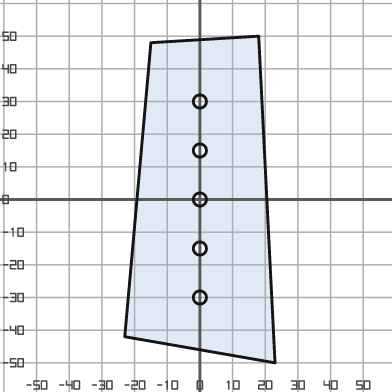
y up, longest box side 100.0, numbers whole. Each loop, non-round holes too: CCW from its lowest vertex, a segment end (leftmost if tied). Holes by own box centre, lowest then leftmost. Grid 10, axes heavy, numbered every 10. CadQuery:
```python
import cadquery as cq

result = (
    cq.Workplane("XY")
    .moveTo(23.0, -50.0)
    .lineTo(18.0, 50.0)
    .lineTo(-15.0, 48.0)
    .lineTo(-23.0, -42.0)
    .close()
    .moveTo(0.0, -30.0)
    .circle(2.0)
    .moveTo(0.0, -15.0)
    .circle(2.0)
    .moveTo(0.0, 0.0)
    .circle(2.0)
    .moveTo(0.0, 15.0)
    .circle(2.0)
    .moveTo(0.0, 30.0)
    .circle(2.0)
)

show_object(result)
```